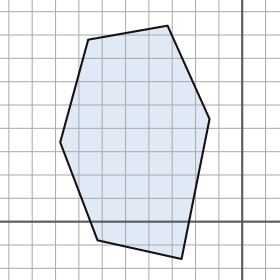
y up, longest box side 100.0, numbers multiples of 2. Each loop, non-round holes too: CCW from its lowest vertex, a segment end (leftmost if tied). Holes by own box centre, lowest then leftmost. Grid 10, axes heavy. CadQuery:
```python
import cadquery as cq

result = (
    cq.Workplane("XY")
    .moveTo(-26.0, -16.0)
    .lineTo(-14.0, 44.0)
    .lineTo(-32.0, 84.0)
    .lineTo(-66.0, 78.0)
    .lineTo(-78.0, 34.0)
    .lineTo(-62.0, -8.0)
    .close()
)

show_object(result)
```